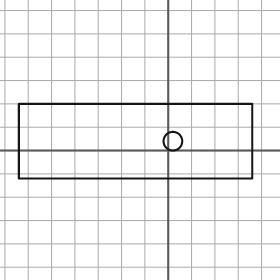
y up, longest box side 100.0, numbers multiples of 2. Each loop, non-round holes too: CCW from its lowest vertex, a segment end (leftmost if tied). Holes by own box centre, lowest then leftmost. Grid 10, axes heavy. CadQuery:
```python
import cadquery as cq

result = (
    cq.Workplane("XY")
    .moveTo(-64.0, -12.0)
    .lineTo(36.0, -12.0)
    .lineTo(36.0, 20.0)
    .lineTo(-64.0, 20.0)
    .close()
    .moveTo(2.0, 4.0)
    .circle(4.0)
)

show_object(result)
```